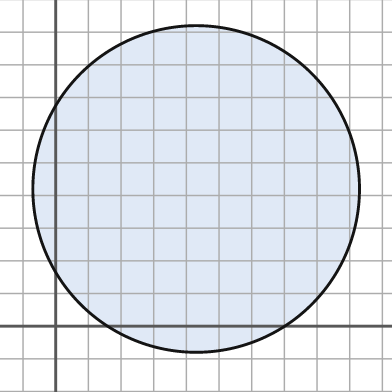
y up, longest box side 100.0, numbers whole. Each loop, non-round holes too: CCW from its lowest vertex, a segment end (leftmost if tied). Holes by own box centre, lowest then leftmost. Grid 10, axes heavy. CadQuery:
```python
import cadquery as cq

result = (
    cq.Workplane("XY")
    .moveTo(43.0, 42.0)
    .circle(50.0)
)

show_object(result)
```